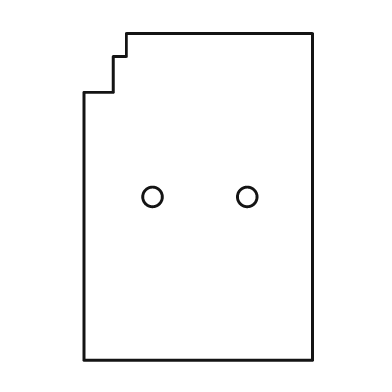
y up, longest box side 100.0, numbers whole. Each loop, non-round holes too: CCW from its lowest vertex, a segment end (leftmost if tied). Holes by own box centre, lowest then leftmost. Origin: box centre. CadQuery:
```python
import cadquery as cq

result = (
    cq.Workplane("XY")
    .moveTo(-35.0, -50.0)
    .lineTo(35.0, -50.0)
    .lineTo(35.0, 50.0)
    .lineTo(-22.0, 50.0)
    .lineTo(-22.0, 43.0)
    .lineTo(-26.0, 43.0)
    .lineTo(-26.0, 32.0)
    .lineTo(-35.0, 32.0)
    .close()
    .moveTo(-14.0, 0.0)
    .circle(3.0)
    .moveTo(15.0, 0.0)
    .circle(3.0)
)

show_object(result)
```